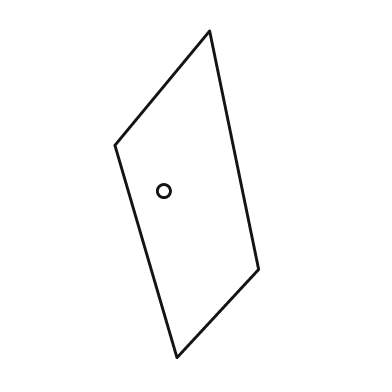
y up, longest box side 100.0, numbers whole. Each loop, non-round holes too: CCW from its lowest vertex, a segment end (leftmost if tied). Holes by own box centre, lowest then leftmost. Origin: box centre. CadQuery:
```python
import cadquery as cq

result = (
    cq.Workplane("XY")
    .moveTo(-3.0, -50.0)
    .lineTo(22.0, -23.0)
    .lineTo(7.0, 50.0)
    .lineTo(-22.0, 15.0)
    .close()
    .moveTo(-7.0, 1.0)
    .circle(2.0)
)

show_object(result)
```